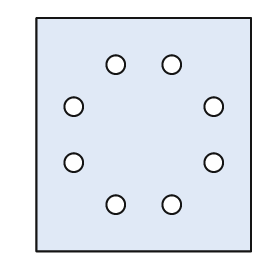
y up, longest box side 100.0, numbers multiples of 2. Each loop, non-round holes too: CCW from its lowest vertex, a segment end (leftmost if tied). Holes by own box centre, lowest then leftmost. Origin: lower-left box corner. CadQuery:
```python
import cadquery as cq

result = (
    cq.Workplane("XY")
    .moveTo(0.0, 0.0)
    .lineTo(92.0, 0.0)
    .lineTo(92.0, 100.0)
    .lineTo(0.0, 100.0)
    .close()
    .moveTo(34.0, 20.0)
    .circle(4.0)
    .moveTo(58.0, 20.0)
    .circle(4.0)
    .moveTo(16.0, 38.0)
    .circle(4.0)
    .moveTo(76.0, 38.0)
    .circle(4.0)
    .moveTo(16.0, 62.0)
    .circle(4.0)
    .moveTo(76.0, 62.0)
    .circle(4.0)
    .moveTo(34.0, 80.0)
    .circle(4.0)
    .moveTo(58.0, 80.0)
    .circle(4.0)
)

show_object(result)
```